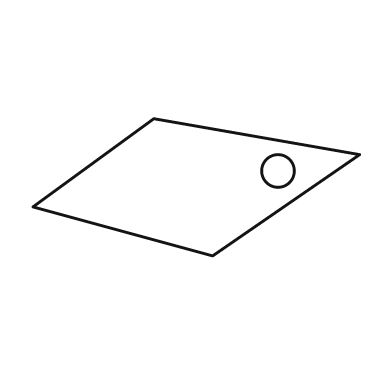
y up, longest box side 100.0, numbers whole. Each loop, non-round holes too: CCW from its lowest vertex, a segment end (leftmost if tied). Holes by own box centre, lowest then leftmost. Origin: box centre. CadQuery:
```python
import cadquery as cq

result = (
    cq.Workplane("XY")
    .moveTo(5.0, -21.0)
    .lineTo(50.0, 10.0)
    .lineTo(-13.0, 21.0)
    .lineTo(-50.0, -6.0)
    .close()
    .moveTo(25.0, 5.0)
    .circle(5.0)
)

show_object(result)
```